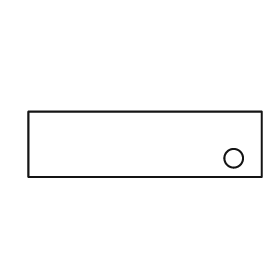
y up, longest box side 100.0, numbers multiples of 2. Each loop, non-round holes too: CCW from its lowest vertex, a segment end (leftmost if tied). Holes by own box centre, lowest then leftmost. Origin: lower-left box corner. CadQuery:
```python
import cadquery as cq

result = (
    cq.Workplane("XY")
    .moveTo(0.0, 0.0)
    .lineTo(100.0, 0.0)
    .lineTo(100.0, 28.0)
    .lineTo(0.0, 28.0)
    .close()
    .moveTo(88.0, 8.0)
    .circle(4.0)
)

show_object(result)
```